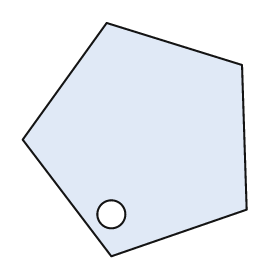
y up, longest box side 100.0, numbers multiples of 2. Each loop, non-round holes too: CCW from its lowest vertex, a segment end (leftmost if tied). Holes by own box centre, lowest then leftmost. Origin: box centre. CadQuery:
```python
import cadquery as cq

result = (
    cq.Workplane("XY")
    .moveTo(-10.0, -50.0)
    .lineTo(48.0, -30.0)
    .lineTo(46.0, 32.0)
    .lineTo(-12.0, 50.0)
    .lineTo(-48.0, 0.0)
    .close()
    .moveTo(-10.0, -32.0)
    .circle(6.0)
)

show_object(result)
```